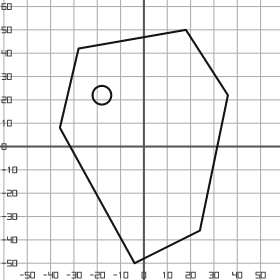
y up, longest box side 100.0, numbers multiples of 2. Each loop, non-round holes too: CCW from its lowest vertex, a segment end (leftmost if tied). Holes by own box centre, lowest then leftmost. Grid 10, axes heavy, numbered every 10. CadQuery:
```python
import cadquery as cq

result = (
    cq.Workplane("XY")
    .moveTo(-4.0, -50.0)
    .lineTo(24.0, -36.0)
    .lineTo(36.0, 22.0)
    .lineTo(18.0, 50.0)
    .lineTo(-28.0, 42.0)
    .lineTo(-36.0, 8.0)
    .close()
    .moveTo(-18.0, 22.0)
    .circle(4.0)
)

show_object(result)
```